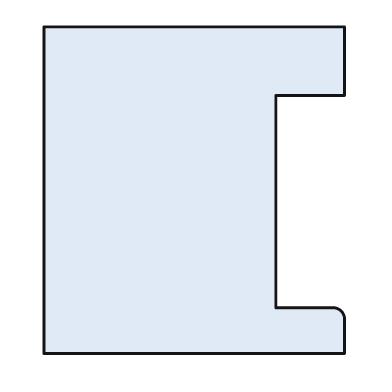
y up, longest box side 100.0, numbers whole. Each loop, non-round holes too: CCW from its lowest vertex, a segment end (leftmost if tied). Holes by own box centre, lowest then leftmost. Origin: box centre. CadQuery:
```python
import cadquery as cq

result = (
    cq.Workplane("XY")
    .moveTo(-46.0, -50.0)
    .lineTo(46.0, -50.0)
    .lineTo(46.0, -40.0)
    .threePointArc((45.0, -37.0), (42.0, -36.0))
    .lineTo(25.0, -36.0)
    .lineTo(25.0, 29.0)
    .lineTo(46.0, 29.0)
    .lineTo(46.0, 50.0)
    .lineTo(-46.0, 50.0)
    .close()
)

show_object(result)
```